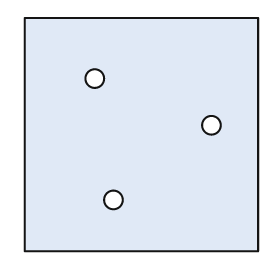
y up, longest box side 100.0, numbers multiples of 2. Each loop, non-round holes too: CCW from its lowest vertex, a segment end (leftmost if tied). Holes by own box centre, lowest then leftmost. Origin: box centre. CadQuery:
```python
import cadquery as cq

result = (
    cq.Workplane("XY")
    .moveTo(-50.0, -50.0)
    .lineTo(50.0, -50.0)
    .lineTo(50.0, 50.0)
    .lineTo(-50.0, 50.0)
    .close()
    .moveTo(-12.0, -28.0)
    .circle(4.0)
    .moveTo(30.0, 4.0)
    .circle(4.0)
    .moveTo(-20.0, 24.0)
    .circle(4.0)
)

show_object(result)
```